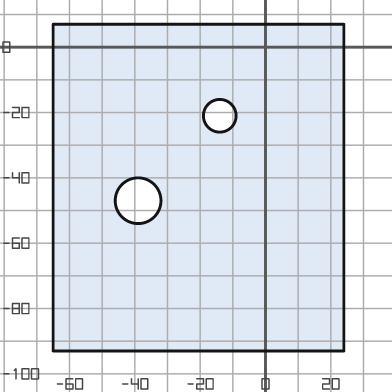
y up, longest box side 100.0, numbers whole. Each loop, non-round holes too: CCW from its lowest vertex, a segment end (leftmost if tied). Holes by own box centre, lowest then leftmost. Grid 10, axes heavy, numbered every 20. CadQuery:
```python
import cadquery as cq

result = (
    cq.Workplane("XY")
    .moveTo(-65.0, -93.0)
    .lineTo(24.0, -93.0)
    .lineTo(24.0, 7.0)
    .lineTo(-65.0, 7.0)
    .close()
    .moveTo(-39.0, -47.0)
    .circle(7.0)
    .moveTo(-14.0, -21.0)
    .circle(5.0)
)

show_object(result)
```